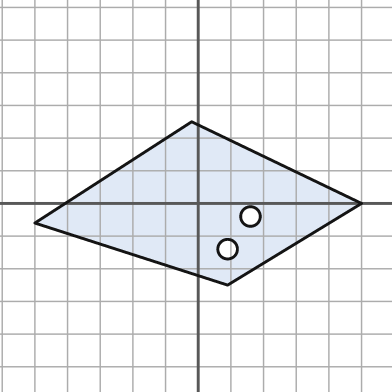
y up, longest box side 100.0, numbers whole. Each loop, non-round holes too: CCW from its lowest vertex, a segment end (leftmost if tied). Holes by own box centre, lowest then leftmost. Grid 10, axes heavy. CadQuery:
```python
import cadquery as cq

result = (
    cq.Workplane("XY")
    .moveTo(9.0, -25.0)
    .lineTo(50.0, 0.0)
    .lineTo(-2.0, 25.0)
    .lineTo(-50.0, -6.0)
    .close()
    .moveTo(9.0, -14.0)
    .circle(3.0)
    .moveTo(16.0, -4.0)
    .circle(3.0)
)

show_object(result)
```